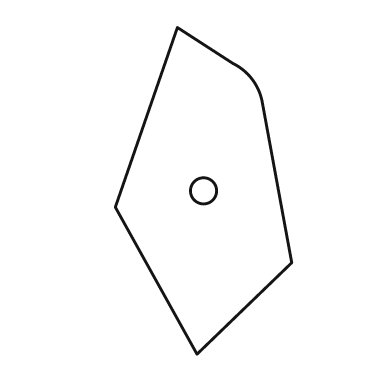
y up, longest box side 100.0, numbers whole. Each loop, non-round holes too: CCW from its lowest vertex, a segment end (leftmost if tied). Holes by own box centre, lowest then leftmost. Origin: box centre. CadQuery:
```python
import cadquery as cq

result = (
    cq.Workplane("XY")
    .moveTo(-2.0, -50.0)
    .lineTo(27.0, -22.0)
    .lineTo(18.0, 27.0)
    .threePointArc((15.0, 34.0), (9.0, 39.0))
    .lineTo(-8.0, 50.0)
    .lineTo(-27.0, -5.0)
    .close()
    .moveTo(0.0, 0.0)
    .circle(4.0)
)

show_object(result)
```